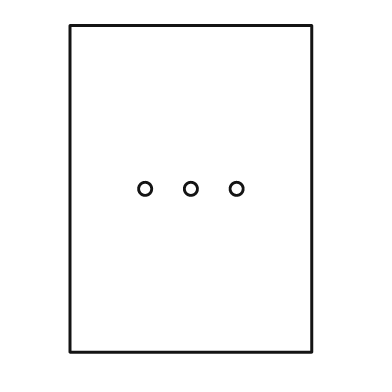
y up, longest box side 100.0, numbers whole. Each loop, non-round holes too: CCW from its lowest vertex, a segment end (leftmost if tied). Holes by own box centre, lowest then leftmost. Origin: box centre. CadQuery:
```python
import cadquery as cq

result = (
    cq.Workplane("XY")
    .moveTo(-37.0, -50.0)
    .lineTo(37.0, -50.0)
    .lineTo(37.0, 50.0)
    .lineTo(-37.0, 50.0)
    .close()
    .moveTo(-14.0, 0.0)
    .circle(2.0)
    .moveTo(0.0, 0.0)
    .circle(2.0)
    .moveTo(14.0, 0.0)
    .circle(2.0)
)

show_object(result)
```